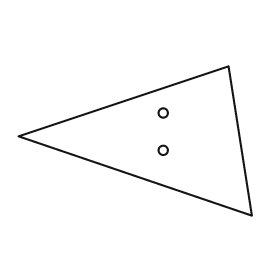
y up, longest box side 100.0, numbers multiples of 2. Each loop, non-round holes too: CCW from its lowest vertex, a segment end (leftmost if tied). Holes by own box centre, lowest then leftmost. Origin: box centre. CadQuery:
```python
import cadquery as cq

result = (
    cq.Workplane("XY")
    .moveTo(50.0, -32.0)
    .lineTo(40.0, 32.0)
    .lineTo(-50.0, 2.0)
    .close()
    .moveTo(12.0, -4.0)
    .circle(2.0)
    .moveTo(12.0, 12.0)
    .circle(2.0)
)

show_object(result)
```